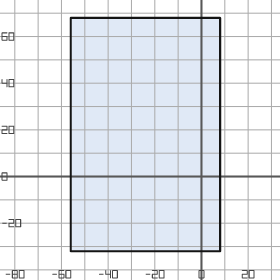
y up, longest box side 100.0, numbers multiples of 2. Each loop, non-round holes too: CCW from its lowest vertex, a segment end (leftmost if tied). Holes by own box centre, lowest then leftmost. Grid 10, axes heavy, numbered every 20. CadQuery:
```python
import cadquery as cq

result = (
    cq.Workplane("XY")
    .moveTo(-56.0, -32.0)
    .lineTo(8.0, -32.0)
    .lineTo(8.0, 68.0)
    .lineTo(-56.0, 68.0)
    .close()
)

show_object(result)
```